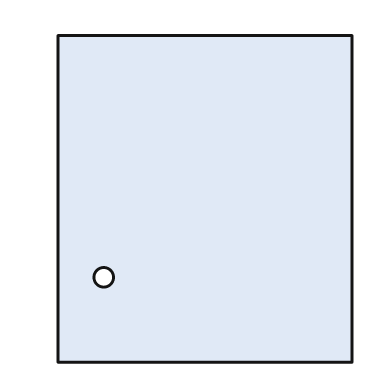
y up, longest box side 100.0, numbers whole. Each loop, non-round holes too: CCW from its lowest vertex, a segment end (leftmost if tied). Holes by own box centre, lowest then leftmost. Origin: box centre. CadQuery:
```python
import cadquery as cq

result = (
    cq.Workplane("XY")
    .moveTo(-45.0, -50.0)
    .lineTo(45.0, -50.0)
    .lineTo(45.0, 50.0)
    .lineTo(-45.0, 50.0)
    .close()
    .moveTo(-31.0, -24.0)
    .circle(3.0)
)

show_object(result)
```